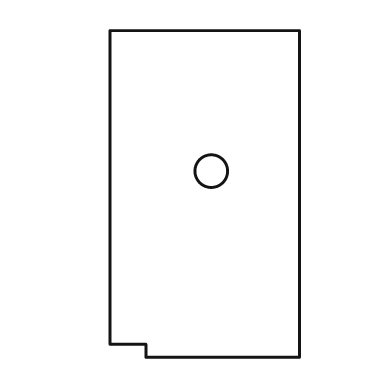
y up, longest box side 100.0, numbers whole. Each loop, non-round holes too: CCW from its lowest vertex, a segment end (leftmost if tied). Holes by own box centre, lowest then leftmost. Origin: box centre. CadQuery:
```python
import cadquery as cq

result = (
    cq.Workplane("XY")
    .moveTo(-18.0, -50.0)
    .lineTo(29.0, -50.0)
    .lineTo(29.0, 50.0)
    .lineTo(-29.0, 50.0)
    .lineTo(-29.0, -46.0)
    .lineTo(-18.0, -46.0)
    .close()
    .moveTo(2.0, 7.0)
    .circle(5.0)
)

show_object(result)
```